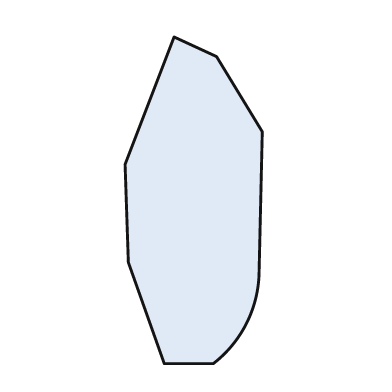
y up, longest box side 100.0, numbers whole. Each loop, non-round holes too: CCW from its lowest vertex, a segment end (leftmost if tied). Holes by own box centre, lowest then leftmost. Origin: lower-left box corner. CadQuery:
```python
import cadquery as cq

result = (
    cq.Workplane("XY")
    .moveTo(12.0, 0.0)
    .lineTo(27.0, 0.0)
    .threePointArc((37.0, 12.0), (41.0, 27.0))
    .lineTo(42.0, 71.0)
    .lineTo(28.0, 94.0)
    .lineTo(15.0, 100.0)
    .lineTo(0.0, 61.0)
    .lineTo(1.0, 31.0)
    .close()
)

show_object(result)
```